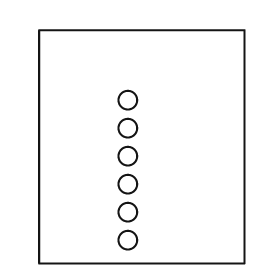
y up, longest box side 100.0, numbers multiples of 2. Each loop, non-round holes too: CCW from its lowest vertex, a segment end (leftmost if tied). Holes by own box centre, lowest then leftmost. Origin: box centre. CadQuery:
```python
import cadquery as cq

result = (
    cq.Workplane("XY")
    .moveTo(-44.0, -50.0)
    .lineTo(44.0, -50.0)
    .lineTo(44.0, 50.0)
    .lineTo(-44.0, 50.0)
    .close()
    .moveTo(-6.0, -40.0)
    .circle(4.0)
    .moveTo(-6.0, -28.0)
    .circle(4.0)
    .moveTo(-6.0, -16.0)
    .circle(4.0)
    .moveTo(-6.0, -4.0)
    .circle(4.0)
    .moveTo(-6.0, 8.0)
    .circle(4.0)
    .moveTo(-6.0, 20.0)
    .circle(4.0)
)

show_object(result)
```